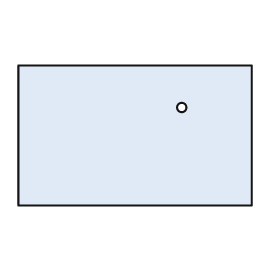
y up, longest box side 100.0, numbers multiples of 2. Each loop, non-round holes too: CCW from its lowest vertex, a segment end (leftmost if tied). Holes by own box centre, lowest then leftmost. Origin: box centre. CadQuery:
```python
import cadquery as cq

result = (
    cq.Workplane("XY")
    .moveTo(-50.0, -30.0)
    .lineTo(50.0, -30.0)
    .lineTo(50.0, 30.0)
    .lineTo(-50.0, 30.0)
    .close()
    .moveTo(20.0, 12.0)
    .circle(2.0)
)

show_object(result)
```